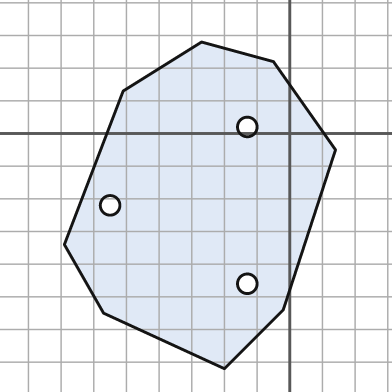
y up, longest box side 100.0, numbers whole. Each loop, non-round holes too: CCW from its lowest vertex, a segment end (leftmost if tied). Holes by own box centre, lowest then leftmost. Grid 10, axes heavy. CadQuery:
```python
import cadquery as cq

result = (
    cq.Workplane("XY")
    .moveTo(-20.0, -72.0)
    .lineTo(-2.0, -54.0)
    .lineTo(14.0, -5.0)
    .lineTo(-5.0, 22.0)
    .lineTo(-27.0, 28.0)
    .lineTo(-51.0, 13.0)
    .lineTo(-69.0, -34.0)
    .lineTo(-57.0, -55.0)
    .close()
    .moveTo(-13.0, -46.0)
    .circle(3.0)
    .moveTo(-55.0, -22.0)
    .circle(3.0)
    .moveTo(-13.0, 2.0)
    .circle(3.0)
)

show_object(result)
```